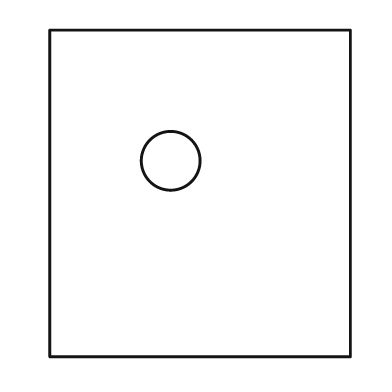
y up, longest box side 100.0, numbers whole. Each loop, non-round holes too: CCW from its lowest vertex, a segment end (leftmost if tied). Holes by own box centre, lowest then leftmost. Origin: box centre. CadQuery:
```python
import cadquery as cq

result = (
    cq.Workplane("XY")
    .moveTo(-46.0, -50.0)
    .lineTo(46.0, -50.0)
    .lineTo(46.0, 50.0)
    .lineTo(-46.0, 50.0)
    .close()
    .moveTo(-9.0, 10.0)
    .circle(9.0)
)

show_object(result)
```